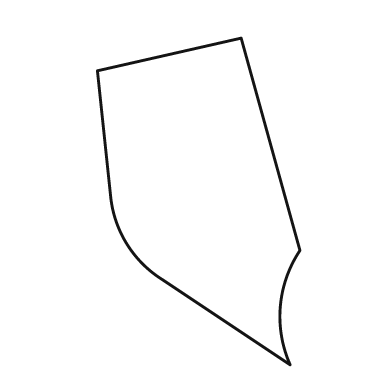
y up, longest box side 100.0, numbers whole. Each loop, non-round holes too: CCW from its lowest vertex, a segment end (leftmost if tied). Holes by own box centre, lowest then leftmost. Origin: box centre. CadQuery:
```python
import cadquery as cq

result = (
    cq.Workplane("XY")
    .moveTo(28.0, -50.0)
    .threePointArc((25.0, -32.0), (31.0, -15.0))
    .lineTo(13.0, 50.0)
    .lineTo(-31.0, 40.0)
    .lineTo(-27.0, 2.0)
    .threePointArc((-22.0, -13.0), (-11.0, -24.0))
    .close()
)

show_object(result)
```